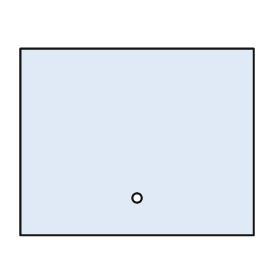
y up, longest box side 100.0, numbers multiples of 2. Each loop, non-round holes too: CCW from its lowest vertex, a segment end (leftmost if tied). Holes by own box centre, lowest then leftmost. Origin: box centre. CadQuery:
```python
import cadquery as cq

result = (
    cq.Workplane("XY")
    .moveTo(-50.0, -40.0)
    .lineTo(50.0, -40.0)
    .lineTo(50.0, 40.0)
    .lineTo(-50.0, 40.0)
    .close()
    .moveTo(0.0, -24.0)
    .circle(2.0)
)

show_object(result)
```